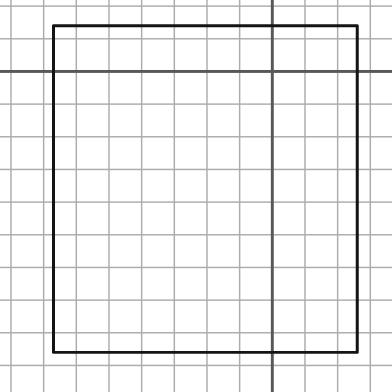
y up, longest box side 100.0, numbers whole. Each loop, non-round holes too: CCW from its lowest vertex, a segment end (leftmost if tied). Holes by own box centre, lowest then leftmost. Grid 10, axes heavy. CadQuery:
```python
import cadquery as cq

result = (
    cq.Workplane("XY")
    .moveTo(-67.0, -86.0)
    .lineTo(26.0, -86.0)
    .lineTo(26.0, 14.0)
    .lineTo(-67.0, 14.0)
    .close()
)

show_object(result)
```